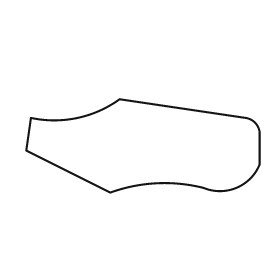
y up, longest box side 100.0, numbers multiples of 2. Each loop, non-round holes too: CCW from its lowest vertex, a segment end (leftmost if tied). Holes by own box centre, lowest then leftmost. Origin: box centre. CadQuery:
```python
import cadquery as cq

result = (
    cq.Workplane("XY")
    .moveTo(-14.0, -20.0)
    .threePointArc((6.0, -16.0), (26.0, -18.0))
    .threePointArc((40.0, -18.0), (50.0, -8.0))
    .lineTo(50.0, 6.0)
    .threePointArc((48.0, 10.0), (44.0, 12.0))
    .lineTo(-10.0, 20.0)
    .threePointArc((-28.0, 12.0), (-48.0, 12.0))
    .lineTo(-50.0, -2.0)
    .close()
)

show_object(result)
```